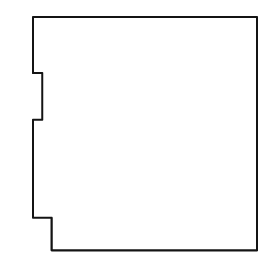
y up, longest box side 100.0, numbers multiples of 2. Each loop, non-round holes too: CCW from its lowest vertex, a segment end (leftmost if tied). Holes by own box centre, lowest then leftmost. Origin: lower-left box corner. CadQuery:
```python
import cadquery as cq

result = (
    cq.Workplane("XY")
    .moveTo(8.0, 0.0)
    .lineTo(96.0, 0.0)
    .lineTo(96.0, 100.0)
    .lineTo(0.0, 100.0)
    .lineTo(0.0, 76.0)
    .lineTo(4.0, 76.0)
    .lineTo(4.0, 56.0)
    .lineTo(0.0, 56.0)
    .lineTo(0.0, 14.0)
    .lineTo(8.0, 14.0)
    .close()
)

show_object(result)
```